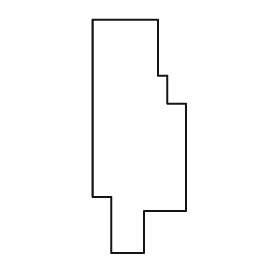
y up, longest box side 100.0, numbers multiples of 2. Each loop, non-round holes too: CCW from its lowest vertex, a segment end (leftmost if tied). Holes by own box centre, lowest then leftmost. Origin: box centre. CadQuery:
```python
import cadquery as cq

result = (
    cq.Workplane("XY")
    .moveTo(-12.0, -50.0)
    .lineTo(2.0, -50.0)
    .lineTo(2.0, -32.0)
    .lineTo(20.0, -32.0)
    .lineTo(20.0, 14.0)
    .lineTo(12.0, 14.0)
    .lineTo(12.0, 26.0)
    .lineTo(8.0, 26.0)
    .lineTo(8.0, 50.0)
    .lineTo(-20.0, 50.0)
    .lineTo(-20.0, -26.0)
    .lineTo(-12.0, -26.0)
    .close()
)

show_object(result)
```